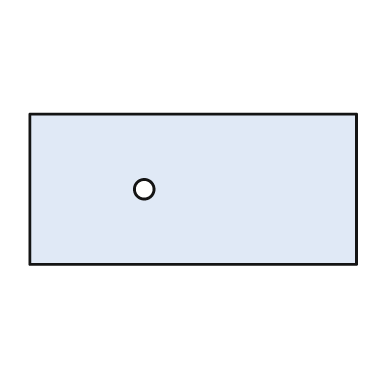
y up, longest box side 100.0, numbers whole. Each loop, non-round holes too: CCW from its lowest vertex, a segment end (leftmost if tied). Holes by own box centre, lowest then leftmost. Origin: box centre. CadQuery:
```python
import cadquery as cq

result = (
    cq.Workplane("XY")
    .moveTo(-50.0, -23.0)
    .lineTo(50.0, -23.0)
    .lineTo(50.0, 23.0)
    .lineTo(-50.0, 23.0)
    .close()
    .moveTo(-15.0, 0.0)
    .circle(3.0)
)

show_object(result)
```